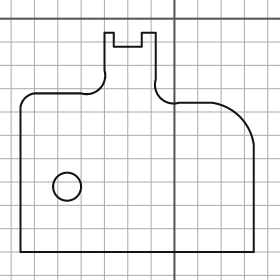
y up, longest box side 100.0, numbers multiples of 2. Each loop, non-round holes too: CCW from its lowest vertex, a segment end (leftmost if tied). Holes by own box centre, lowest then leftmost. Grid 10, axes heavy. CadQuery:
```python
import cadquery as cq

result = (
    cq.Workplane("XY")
    .moveTo(-66.0, -100.0)
    .lineTo(34.0, -100.0)
    .lineTo(34.0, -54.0)
    .threePointArc((28.0, -42.0), (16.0, -36.0))
    .lineTo(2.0, -36.0)
    .threePointArc((-6.0, -34.0), (-8.0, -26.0))
    .lineTo(-8.0, -6.0)
    .lineTo(-14.0, -6.0)
    .lineTo(-14.0, -12.0)
    .lineTo(-26.0, -12.0)
    .lineTo(-26.0, -6.0)
    .lineTo(-30.0, -6.0)
    .lineTo(-30.0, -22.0)
    .threePointArc((-32.0, -30.0), (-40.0, -32.0))
    .lineTo(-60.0, -32.0)
    .threePointArc((-64.0, -34.0), (-66.0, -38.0))
    .close()
    .moveTo(-46.0, -72.0)
    .circle(6.0)
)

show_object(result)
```